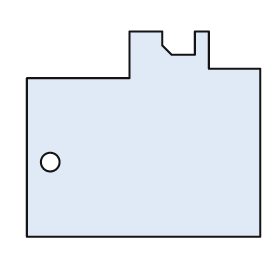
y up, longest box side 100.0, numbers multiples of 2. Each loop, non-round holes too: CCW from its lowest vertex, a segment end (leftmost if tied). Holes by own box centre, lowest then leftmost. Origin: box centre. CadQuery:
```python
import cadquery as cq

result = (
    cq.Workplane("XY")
    .moveTo(-50.0, -44.0)
    .lineTo(50.0, -44.0)
    .lineTo(50.0, 28.0)
    .lineTo(28.0, 28.0)
    .lineTo(28.0, 44.0)
    .lineTo(22.0, 44.0)
    .lineTo(22.0, 34.0)
    .lineTo(12.0, 34.0)
    .lineTo(8.0, 38.0)
    .lineTo(8.0, 44.0)
    .lineTo(-6.0, 44.0)
    .lineTo(-6.0, 24.0)
    .lineTo(-50.0, 24.0)
    .close()
    .moveTo(-40.0, -12.0)
    .circle(4.0)
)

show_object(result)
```